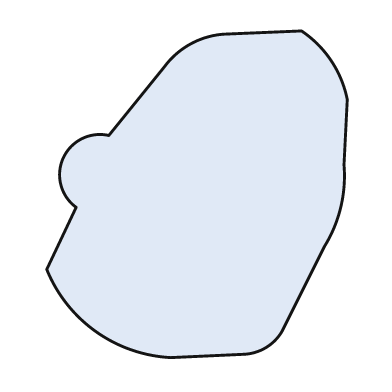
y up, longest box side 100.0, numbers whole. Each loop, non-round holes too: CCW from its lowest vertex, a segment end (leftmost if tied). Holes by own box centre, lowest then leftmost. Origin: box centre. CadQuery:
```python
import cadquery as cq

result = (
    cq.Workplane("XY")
    .moveTo(-8.0, -50.0)
    .lineTo(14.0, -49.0)
    .threePointArc((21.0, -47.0), (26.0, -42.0))
    .lineTo(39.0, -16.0)
    .threePointArc((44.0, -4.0), (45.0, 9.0))
    .lineTo(46.0, 29.0)
    .threePointArc((41.0, 41.0), (32.0, 50.0))
    .lineTo(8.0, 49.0)
    .threePointArc((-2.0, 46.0), (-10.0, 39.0))
    .lineTo(-27.0, 18.0)
    .threePointArc((-41.0, 11.0), (-37.0, -4.0))
    .lineTo(-46.0, -23.0)
    .threePointArc((-31.0, -42.0), (-8.0, -50.0))
    .close()
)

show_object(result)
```